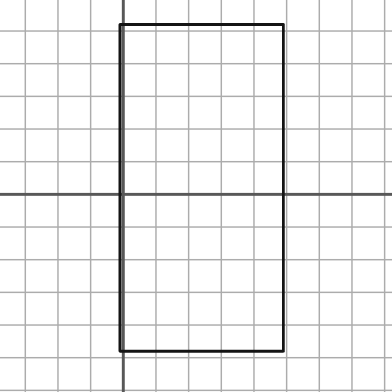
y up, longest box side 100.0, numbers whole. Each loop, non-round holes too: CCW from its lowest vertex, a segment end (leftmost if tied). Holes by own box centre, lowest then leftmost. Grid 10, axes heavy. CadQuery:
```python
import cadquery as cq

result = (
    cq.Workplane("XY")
    .moveTo(-1.0, -48.0)
    .lineTo(49.0, -48.0)
    .lineTo(49.0, 52.0)
    .lineTo(-1.0, 52.0)
    .close()
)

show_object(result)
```